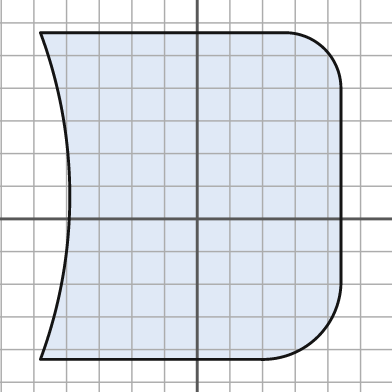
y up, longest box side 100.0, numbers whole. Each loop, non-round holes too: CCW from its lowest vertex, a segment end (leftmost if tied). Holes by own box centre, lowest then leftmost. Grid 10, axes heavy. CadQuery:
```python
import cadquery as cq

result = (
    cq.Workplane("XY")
    .moveTo(-48.0, -43.0)
    .lineTo(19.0, -43.0)
    .threePointArc((37.0, -36.0), (44.0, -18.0))
    .lineTo(44.0, 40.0)
    .threePointArc((39.0, 52.0), (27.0, 57.0))
    .lineTo(-48.0, 57.0)
    .threePointArc((-39.0, 7.0), (-48.0, -43.0))
    .close()
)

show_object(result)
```